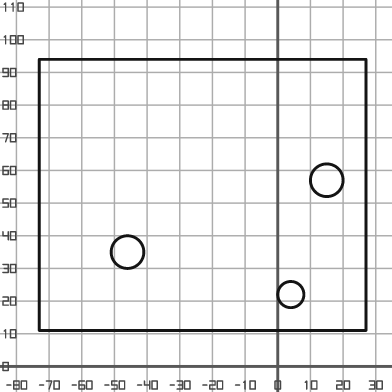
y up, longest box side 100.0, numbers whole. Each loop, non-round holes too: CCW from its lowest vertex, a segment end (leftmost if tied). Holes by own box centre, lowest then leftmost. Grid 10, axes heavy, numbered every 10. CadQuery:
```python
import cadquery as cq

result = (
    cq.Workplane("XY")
    .moveTo(-73.0, 11.0)
    .lineTo(27.0, 11.0)
    .lineTo(27.0, 94.0)
    .lineTo(-73.0, 94.0)
    .close()
    .moveTo(4.0, 22.0)
    .circle(4.0)
    .moveTo(-46.0, 35.0)
    .circle(5.0)
    .moveTo(15.0, 57.0)
    .circle(5.0)
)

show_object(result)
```